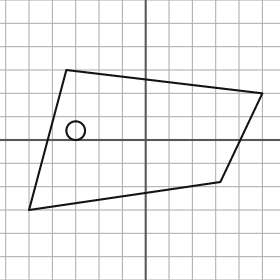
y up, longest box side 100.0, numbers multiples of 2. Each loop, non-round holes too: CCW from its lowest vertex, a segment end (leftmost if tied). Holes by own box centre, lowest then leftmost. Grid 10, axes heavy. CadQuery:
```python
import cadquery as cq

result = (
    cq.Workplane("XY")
    .moveTo(-50.0, -30.0)
    .lineTo(32.0, -18.0)
    .lineTo(50.0, 20.0)
    .lineTo(-34.0, 30.0)
    .close()
    .moveTo(-30.0, 4.0)
    .circle(4.0)
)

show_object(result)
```